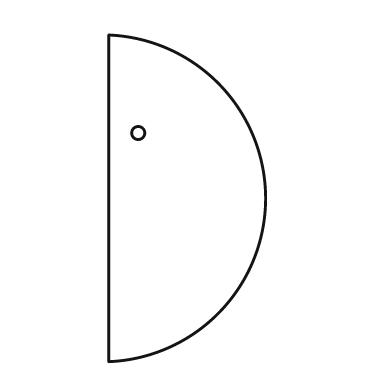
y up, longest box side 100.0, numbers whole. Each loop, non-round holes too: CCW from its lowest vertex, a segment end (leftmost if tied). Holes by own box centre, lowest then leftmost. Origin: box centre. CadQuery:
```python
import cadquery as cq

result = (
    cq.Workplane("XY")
    .moveTo(-24.0, -50.0)
    .threePointArc((24.0, 0.0), (-24.0, 50.0))
    .close()
    .moveTo(-15.0, 20.0)
    .circle(2.0)
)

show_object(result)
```